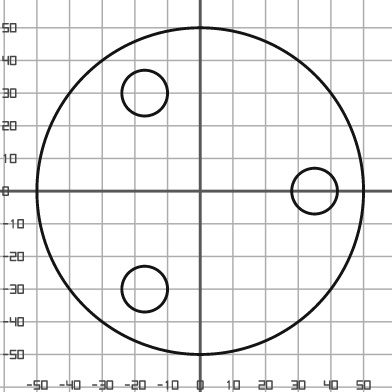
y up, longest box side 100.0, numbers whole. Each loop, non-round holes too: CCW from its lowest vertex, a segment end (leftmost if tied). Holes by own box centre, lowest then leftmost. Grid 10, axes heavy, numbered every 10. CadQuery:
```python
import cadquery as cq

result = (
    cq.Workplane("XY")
    .moveTo(0.0, 0.0)
    .circle(50.0)
    .moveTo(-17.0, -30.0)
    .circle(7.0)
    .moveTo(35.0, 0.0)
    .circle(7.0)
    .moveTo(-17.0, 30.0)
    .circle(7.0)
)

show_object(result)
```